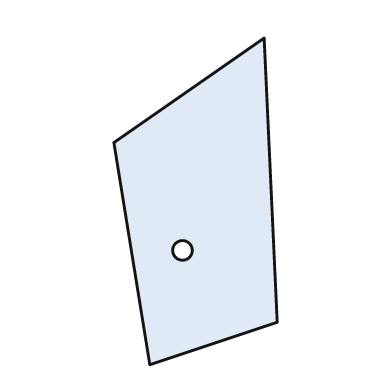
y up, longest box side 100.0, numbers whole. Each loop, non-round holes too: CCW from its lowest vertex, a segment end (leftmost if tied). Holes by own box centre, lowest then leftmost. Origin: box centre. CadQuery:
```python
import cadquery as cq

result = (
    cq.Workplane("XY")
    .moveTo(-14.0, -50.0)
    .lineTo(25.0, -37.0)
    .lineTo(21.0, 50.0)
    .lineTo(-25.0, 18.0)
    .close()
    .moveTo(-4.0, -15.0)
    .circle(3.0)
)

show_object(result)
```